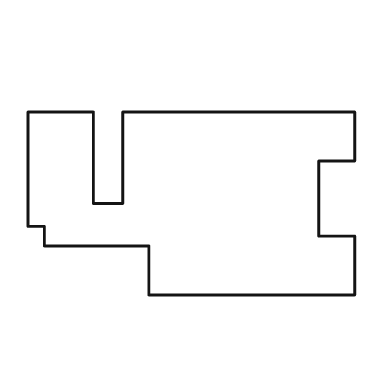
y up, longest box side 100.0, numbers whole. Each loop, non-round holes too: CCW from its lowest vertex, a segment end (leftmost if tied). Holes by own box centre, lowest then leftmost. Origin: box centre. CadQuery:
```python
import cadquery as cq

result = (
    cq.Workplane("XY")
    .moveTo(-13.0, -28.0)
    .lineTo(50.0, -28.0)
    .lineTo(50.0, -10.0)
    .lineTo(39.0, -10.0)
    .lineTo(39.0, 13.0)
    .lineTo(50.0, 13.0)
    .lineTo(50.0, 28.0)
    .lineTo(-21.0, 28.0)
    .lineTo(-21.0, 0.0)
    .lineTo(-30.0, 0.0)
    .lineTo(-30.0, 28.0)
    .lineTo(-50.0, 28.0)
    .lineTo(-50.0, -7.0)
    .lineTo(-45.0, -7.0)
    .lineTo(-45.0, -13.0)
    .lineTo(-13.0, -13.0)
    .close()
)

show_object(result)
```